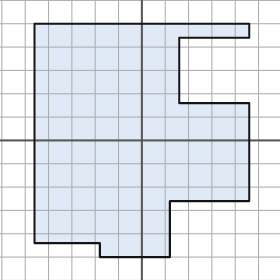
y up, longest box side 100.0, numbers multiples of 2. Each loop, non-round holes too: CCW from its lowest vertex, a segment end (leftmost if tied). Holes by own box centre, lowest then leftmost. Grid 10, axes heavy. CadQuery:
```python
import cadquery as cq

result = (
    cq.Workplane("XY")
    .moveTo(-18.0, -50.0)
    .lineTo(12.0, -50.0)
    .lineTo(12.0, -26.0)
    .lineTo(46.0, -26.0)
    .lineTo(46.0, 16.0)
    .lineTo(16.0, 16.0)
    .lineTo(16.0, 44.0)
    .lineTo(46.0, 44.0)
    .lineTo(46.0, 50.0)
    .lineTo(-46.0, 50.0)
    .lineTo(-46.0, -44.0)
    .lineTo(-18.0, -44.0)
    .close()
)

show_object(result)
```